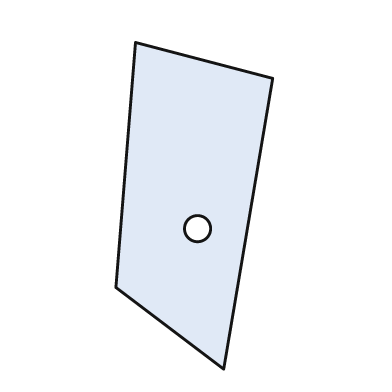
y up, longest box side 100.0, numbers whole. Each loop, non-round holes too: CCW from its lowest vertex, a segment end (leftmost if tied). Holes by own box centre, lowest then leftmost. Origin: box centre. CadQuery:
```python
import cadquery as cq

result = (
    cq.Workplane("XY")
    .moveTo(9.0, -50.0)
    .lineTo(24.0, 39.0)
    .lineTo(-18.0, 50.0)
    .lineTo(-24.0, -25.0)
    .close()
    .moveTo(1.0, -7.0)
    .circle(4.0)
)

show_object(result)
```